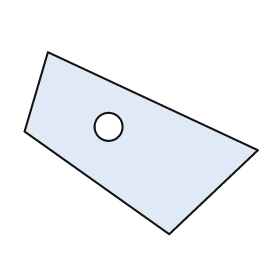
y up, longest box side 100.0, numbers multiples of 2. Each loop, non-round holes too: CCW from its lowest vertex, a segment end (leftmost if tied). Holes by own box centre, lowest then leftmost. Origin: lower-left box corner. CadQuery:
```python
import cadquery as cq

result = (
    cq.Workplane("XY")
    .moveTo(62.0, 0.0)
    .lineTo(100.0, 36.0)
    .lineTo(10.0, 78.0)
    .lineTo(0.0, 44.0)
    .close()
    .moveTo(36.0, 46.0)
    .circle(6.0)
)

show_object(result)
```